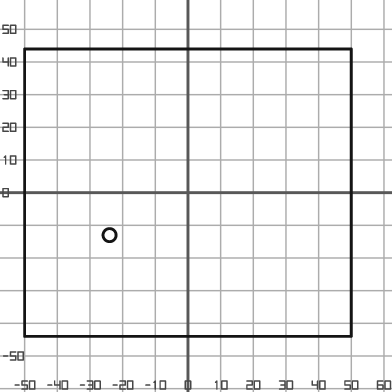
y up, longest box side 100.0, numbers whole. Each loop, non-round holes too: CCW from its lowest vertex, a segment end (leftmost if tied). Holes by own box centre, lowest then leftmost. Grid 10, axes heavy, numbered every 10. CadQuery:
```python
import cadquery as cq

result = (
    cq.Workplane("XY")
    .moveTo(-50.0, -44.0)
    .lineTo(50.0, -44.0)
    .lineTo(50.0, 44.0)
    .lineTo(-50.0, 44.0)
    .close()
    .moveTo(-24.0, -13.0)
    .circle(2.0)
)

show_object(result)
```